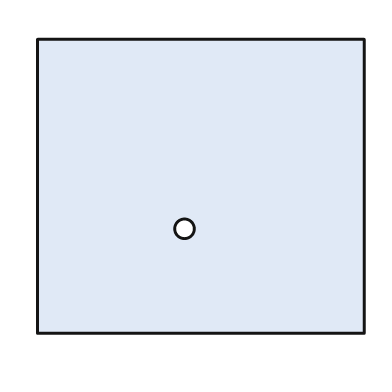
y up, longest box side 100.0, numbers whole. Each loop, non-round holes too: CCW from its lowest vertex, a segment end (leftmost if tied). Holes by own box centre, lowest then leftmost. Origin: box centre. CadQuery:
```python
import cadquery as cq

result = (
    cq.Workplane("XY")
    .moveTo(-50.0, -45.0)
    .lineTo(50.0, -45.0)
    .lineTo(50.0, 45.0)
    .lineTo(-50.0, 45.0)
    .close()
    .moveTo(-5.0, -13.0)
    .circle(3.0)
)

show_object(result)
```